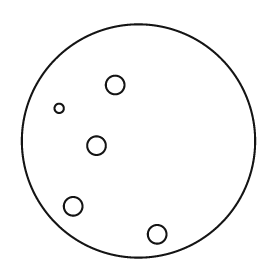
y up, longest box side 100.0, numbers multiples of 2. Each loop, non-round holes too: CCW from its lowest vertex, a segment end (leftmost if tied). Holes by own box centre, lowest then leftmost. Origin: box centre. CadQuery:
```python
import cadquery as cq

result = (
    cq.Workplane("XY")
    .moveTo(0.0, 0.0)
    .circle(50.0)
    .moveTo(8.0, -40.0)
    .circle(4.0)
    .moveTo(-28.0, -28.0)
    .circle(4.0)
    .moveTo(-18.0, -2.0)
    .circle(4.0)
    .moveTo(-34.0, 14.0)
    .circle(2.0)
    .moveTo(-10.0, 24.0)
    .circle(4.0)
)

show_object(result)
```